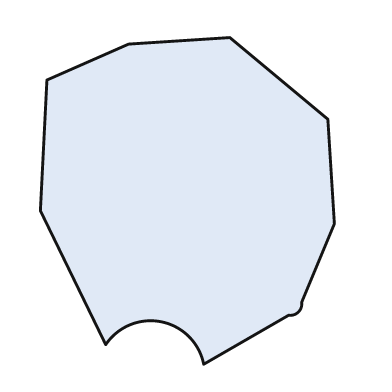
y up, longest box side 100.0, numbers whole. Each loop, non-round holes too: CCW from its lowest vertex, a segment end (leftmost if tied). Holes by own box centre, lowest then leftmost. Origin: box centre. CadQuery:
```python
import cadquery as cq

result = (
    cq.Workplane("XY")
    .moveTo(5.0, -50.0)
    .lineTo(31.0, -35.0)
    .threePointArc((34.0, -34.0), (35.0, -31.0))
    .lineTo(45.0, -7.0)
    .lineTo(43.0, 25.0)
    .lineTo(13.0, 50.0)
    .lineTo(-18.0, 48.0)
    .lineTo(-43.0, 37.0)
    .lineTo(-45.0, -3.0)
    .lineTo(-25.0, -44.0)
    .threePointArc((-8.0, -37.0), (5.0, -50.0))
    .close()
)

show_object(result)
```